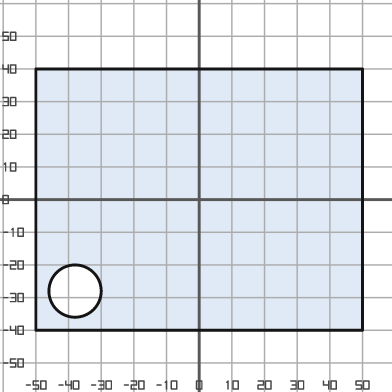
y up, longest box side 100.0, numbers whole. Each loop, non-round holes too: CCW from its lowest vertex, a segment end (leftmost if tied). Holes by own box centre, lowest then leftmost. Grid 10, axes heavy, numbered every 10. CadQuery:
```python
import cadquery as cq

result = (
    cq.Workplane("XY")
    .moveTo(-50.0, -40.0)
    .lineTo(50.0, -40.0)
    .lineTo(50.0, 40.0)
    .lineTo(-50.0, 40.0)
    .close()
    .moveTo(-38.0, -28.0)
    .circle(8.0)
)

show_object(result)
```